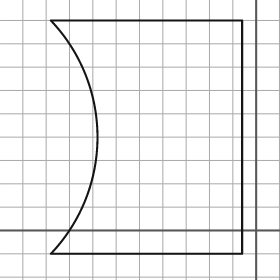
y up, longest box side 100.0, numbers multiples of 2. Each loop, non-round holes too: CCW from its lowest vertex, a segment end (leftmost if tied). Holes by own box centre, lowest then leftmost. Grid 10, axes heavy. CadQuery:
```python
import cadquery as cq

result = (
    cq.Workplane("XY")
    .moveTo(-88.0, -10.0)
    .lineTo(-6.0, -10.0)
    .lineTo(-6.0, 90.0)
    .lineTo(-88.0, 90.0)
    .threePointArc((-68.0, 40.0), (-88.0, -10.0))
    .close()
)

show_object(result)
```